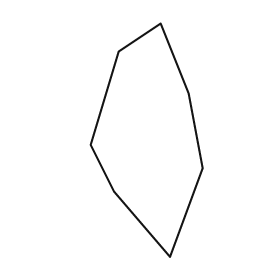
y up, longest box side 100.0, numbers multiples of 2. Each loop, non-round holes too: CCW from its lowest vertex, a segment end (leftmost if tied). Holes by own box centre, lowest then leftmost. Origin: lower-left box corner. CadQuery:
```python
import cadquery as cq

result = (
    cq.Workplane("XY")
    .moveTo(34.0, 0.0)
    .lineTo(48.0, 38.0)
    .lineTo(42.0, 70.0)
    .lineTo(30.0, 100.0)
    .lineTo(12.0, 88.0)
    .lineTo(0.0, 48.0)
    .lineTo(10.0, 28.0)
    .close()
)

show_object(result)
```